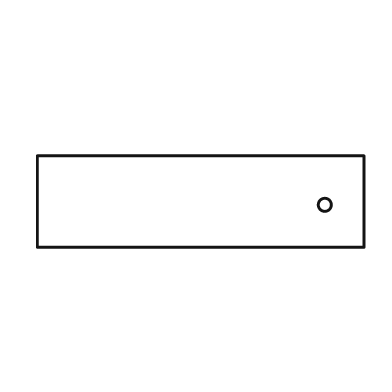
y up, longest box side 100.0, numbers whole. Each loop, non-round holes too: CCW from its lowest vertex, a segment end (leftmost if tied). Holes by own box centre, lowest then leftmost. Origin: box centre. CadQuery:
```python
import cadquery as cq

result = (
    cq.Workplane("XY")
    .moveTo(-50.0, -14.0)
    .lineTo(50.0, -14.0)
    .lineTo(50.0, 14.0)
    .lineTo(-50.0, 14.0)
    .close()
    .moveTo(38.0, -1.0)
    .circle(2.0)
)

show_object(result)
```